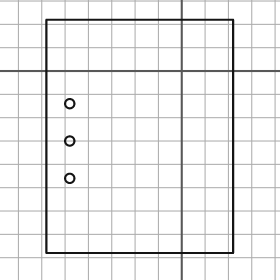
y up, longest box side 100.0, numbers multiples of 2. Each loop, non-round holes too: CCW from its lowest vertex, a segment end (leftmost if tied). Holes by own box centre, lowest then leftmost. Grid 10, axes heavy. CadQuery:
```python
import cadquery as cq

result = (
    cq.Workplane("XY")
    .moveTo(-58.0, -78.0)
    .lineTo(22.0, -78.0)
    .lineTo(22.0, 22.0)
    .lineTo(-58.0, 22.0)
    .close()
    .moveTo(-48.0, -46.0)
    .circle(2.0)
    .moveTo(-48.0, -30.0)
    .circle(2.0)
    .moveTo(-48.0, -14.0)
    .circle(2.0)
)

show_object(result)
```